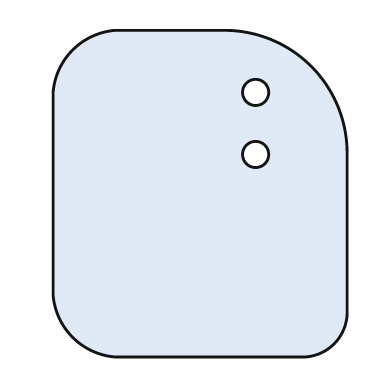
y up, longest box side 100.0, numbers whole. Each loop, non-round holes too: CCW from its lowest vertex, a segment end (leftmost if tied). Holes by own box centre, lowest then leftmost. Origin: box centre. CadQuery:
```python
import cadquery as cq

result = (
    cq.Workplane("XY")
    .moveTo(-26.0, -50.0)
    .lineTo(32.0, -50.0)
    .threePointArc((41.0, -46.0), (45.0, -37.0))
    .lineTo(45.0, 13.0)
    .threePointArc((34.0, 39.0), (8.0, 50.0))
    .lineTo(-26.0, 50.0)
    .threePointArc((-39.0, 44.0), (-45.0, 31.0))
    .lineTo(-45.0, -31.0)
    .threePointArc((-39.0, -44.0), (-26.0, -50.0))
    .close()
    .moveTo(17.0, 12.0)
    .circle(4.0)
    .moveTo(17.0, 31.0)
    .circle(4.0)
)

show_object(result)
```